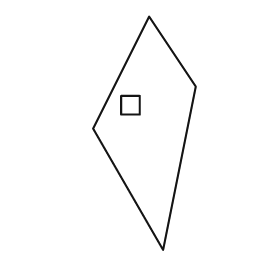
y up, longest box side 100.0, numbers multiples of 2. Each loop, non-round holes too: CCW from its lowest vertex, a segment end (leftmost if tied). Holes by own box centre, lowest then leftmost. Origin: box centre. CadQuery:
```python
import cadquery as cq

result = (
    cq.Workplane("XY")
    .moveTo(8.0, -50.0)
    .lineTo(22.0, 20.0)
    .lineTo(2.0, 50.0)
    .lineTo(-22.0, 2.0)
    .close()
    .moveTo(-10.0, 8.0)
    .lineTo(-2.0, 8.0)
    .lineTo(-2.0, 16.0)
    .lineTo(-10.0, 16.0)
    .close()
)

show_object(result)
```